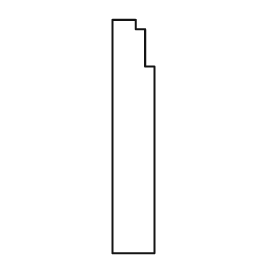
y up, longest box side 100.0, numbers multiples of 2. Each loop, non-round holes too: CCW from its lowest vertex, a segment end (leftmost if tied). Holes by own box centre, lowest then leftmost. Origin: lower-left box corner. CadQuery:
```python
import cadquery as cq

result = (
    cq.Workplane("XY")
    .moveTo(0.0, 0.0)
    .lineTo(18.0, 0.0)
    .lineTo(18.0, 80.0)
    .lineTo(14.0, 80.0)
    .lineTo(14.0, 96.0)
    .lineTo(10.0, 96.0)
    .lineTo(10.0, 100.0)
    .lineTo(0.0, 100.0)
    .close()
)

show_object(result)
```